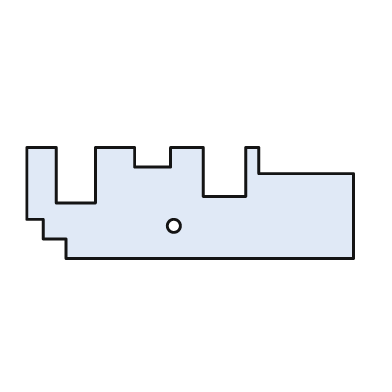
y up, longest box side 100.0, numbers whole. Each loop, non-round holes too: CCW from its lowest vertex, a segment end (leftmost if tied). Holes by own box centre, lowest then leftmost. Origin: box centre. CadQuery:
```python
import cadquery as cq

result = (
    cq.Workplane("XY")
    .moveTo(-38.0, -17.0)
    .lineTo(50.0, -17.0)
    .lineTo(50.0, 9.0)
    .lineTo(21.0, 9.0)
    .lineTo(21.0, 17.0)
    .lineTo(17.0, 17.0)
    .lineTo(17.0, 2.0)
    .lineTo(4.0, 2.0)
    .lineTo(4.0, 17.0)
    .lineTo(-6.0, 17.0)
    .lineTo(-6.0, 11.0)
    .lineTo(-17.0, 11.0)
    .lineTo(-17.0, 17.0)
    .lineTo(-29.0, 17.0)
    .lineTo(-29.0, 0.0)
    .lineTo(-41.0, 0.0)
    .lineTo(-41.0, 17.0)
    .lineTo(-50.0, 17.0)
    .lineTo(-50.0, -5.0)
    .lineTo(-45.0, -5.0)
    .lineTo(-45.0, -11.0)
    .lineTo(-38.0, -11.0)
    .close()
    .moveTo(-5.0, -7.0)
    .circle(2.0)
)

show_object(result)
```